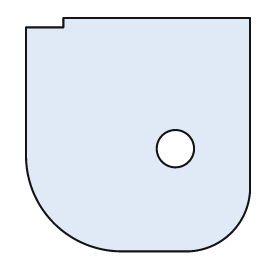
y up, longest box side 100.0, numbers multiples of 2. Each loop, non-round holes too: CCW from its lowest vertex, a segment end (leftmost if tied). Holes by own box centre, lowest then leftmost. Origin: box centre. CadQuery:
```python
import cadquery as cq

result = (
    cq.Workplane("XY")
    .moveTo(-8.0, -50.0)
    .lineTo(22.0, -50.0)
    .threePointArc((40.0, -42.0), (48.0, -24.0))
    .lineTo(48.0, 50.0)
    .lineTo(-32.0, 50.0)
    .lineTo(-32.0, 46.0)
    .lineTo(-48.0, 46.0)
    .lineTo(-48.0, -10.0)
    .threePointArc((-36.0, -38.0), (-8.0, -50.0))
    .close()
    .moveTo(16.0, -6.0)
    .circle(8.0)
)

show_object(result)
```